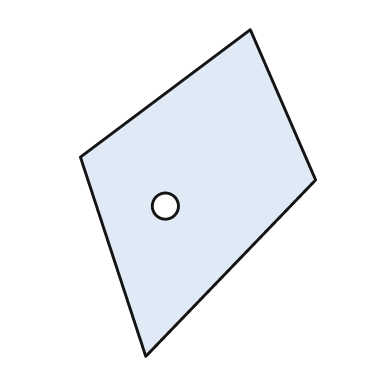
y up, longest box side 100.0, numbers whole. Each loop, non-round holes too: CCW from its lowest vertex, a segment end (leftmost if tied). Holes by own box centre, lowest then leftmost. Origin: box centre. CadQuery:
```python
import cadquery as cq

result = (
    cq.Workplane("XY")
    .moveTo(-16.0, -50.0)
    .lineTo(36.0, 4.0)
    .lineTo(16.0, 50.0)
    .lineTo(-36.0, 11.0)
    .close()
    .moveTo(-10.0, -4.0)
    .circle(4.0)
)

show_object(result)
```